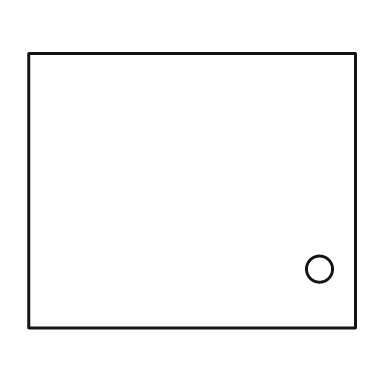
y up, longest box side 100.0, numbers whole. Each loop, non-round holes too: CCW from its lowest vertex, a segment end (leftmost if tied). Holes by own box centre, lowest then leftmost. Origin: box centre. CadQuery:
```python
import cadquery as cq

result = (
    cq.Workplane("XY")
    .moveTo(-50.0, -42.0)
    .lineTo(50.0, -42.0)
    .lineTo(50.0, 42.0)
    .lineTo(-50.0, 42.0)
    .close()
    .moveTo(39.0, -24.0)
    .circle(4.0)
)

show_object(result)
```